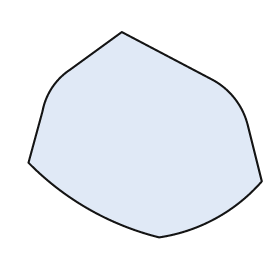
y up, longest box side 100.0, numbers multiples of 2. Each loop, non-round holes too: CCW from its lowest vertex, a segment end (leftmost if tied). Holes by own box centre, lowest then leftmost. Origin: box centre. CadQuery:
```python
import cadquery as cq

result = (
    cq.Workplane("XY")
    .moveTo(6.0, -44.0)
    .threePointArc((30.0, -36.0), (50.0, -20.0))
    .lineTo(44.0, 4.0)
    .threePointArc((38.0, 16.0), (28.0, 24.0))
    .lineTo(-10.0, 44.0)
    .lineTo(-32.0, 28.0)
    .threePointArc((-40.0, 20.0), (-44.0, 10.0))
    .lineTo(-50.0, -12.0)
    .threePointArc((-24.0, -32.0), (6.0, -44.0))
    .close()
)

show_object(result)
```